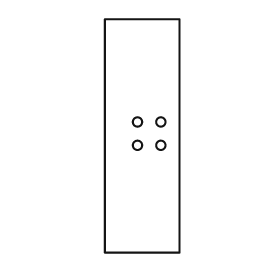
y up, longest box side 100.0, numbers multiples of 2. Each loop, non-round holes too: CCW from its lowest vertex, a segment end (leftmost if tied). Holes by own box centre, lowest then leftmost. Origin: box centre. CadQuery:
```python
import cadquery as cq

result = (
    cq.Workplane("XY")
    .moveTo(-16.0, -50.0)
    .lineTo(16.0, -50.0)
    .lineTo(16.0, 50.0)
    .lineTo(-16.0, 50.0)
    .close()
    .moveTo(-2.0, -4.0)
    .circle(2.0)
    .moveTo(8.0, -4.0)
    .circle(2.0)
    .moveTo(-2.0, 6.0)
    .circle(2.0)
    .moveTo(8.0, 6.0)
    .circle(2.0)
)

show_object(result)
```